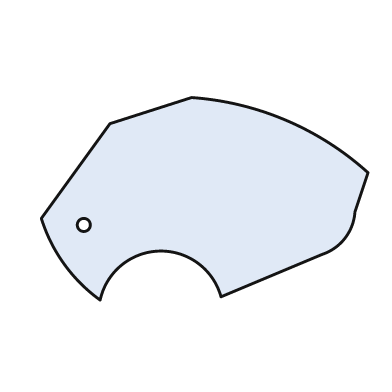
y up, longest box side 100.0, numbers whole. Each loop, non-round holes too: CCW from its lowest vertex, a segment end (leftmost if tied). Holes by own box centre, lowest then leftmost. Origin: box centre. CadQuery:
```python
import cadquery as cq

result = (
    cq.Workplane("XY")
    .moveTo(-32.0, -31.0)
    .threePointArc((-14.0, -16.0), (5.0, -30.0))
    .lineTo(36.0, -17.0)
    .threePointArc((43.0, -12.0), (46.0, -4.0))
    .lineTo(50.0, 8.0)
    .threePointArc((25.0, 24.0), (-4.0, 31.0))
    .lineTo(-29.0, 23.0)
    .lineTo(-50.0, -6.0)
    .threePointArc((-43.0, -20.0), (-32.0, -31.0))
    .close()
    .moveTo(-37.0, -8.0)
    .circle(2.0)
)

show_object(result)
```